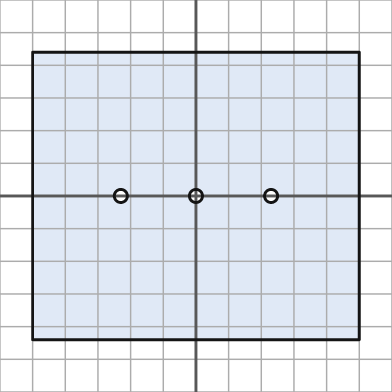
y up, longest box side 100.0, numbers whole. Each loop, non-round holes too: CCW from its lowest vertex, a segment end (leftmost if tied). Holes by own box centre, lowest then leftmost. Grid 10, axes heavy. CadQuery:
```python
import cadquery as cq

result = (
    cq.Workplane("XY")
    .moveTo(-50.0, -44.0)
    .lineTo(50.0, -44.0)
    .lineTo(50.0, 44.0)
    .lineTo(-50.0, 44.0)
    .close()
    .moveTo(-23.0, 0.0)
    .circle(2.0)
    .moveTo(0.0, 0.0)
    .circle(2.0)
    .moveTo(23.0, 0.0)
    .circle(2.0)
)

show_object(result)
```